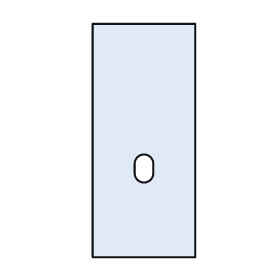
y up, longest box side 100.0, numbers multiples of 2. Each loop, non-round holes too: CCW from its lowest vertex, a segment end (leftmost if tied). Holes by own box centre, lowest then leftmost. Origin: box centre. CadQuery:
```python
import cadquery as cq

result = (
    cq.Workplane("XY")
    .moveTo(-22.0, -50.0)
    .lineTo(22.0, -50.0)
    .lineTo(22.0, 50.0)
    .lineTo(-22.0, 50.0)
    .close()
    .moveTo(-4.0, -14.0)
    .threePointArc((0.0, -18.0), (4.0, -14.0))
    .lineTo(4.0, -10.0)
    .threePointArc((0.0, -6.0), (-4.0, -10.0))
    .close()
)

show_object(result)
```